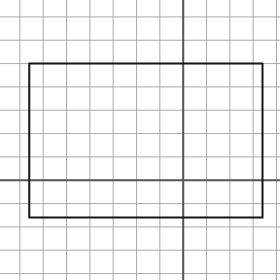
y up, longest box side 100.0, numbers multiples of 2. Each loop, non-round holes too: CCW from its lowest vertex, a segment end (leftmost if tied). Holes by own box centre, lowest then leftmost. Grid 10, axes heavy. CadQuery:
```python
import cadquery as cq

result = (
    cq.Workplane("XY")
    .moveTo(-66.0, -16.0)
    .lineTo(34.0, -16.0)
    .lineTo(34.0, 50.0)
    .lineTo(-66.0, 50.0)
    .close()
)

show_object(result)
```